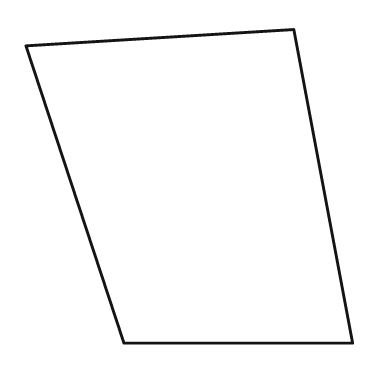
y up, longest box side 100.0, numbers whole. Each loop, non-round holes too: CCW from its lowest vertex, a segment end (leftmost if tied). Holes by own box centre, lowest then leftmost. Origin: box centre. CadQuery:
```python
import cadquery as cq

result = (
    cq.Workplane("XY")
    .moveTo(-20.0, -48.0)
    .lineTo(50.0, -48.0)
    .lineTo(32.0, 48.0)
    .lineTo(-50.0, 43.0)
    .close()
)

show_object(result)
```